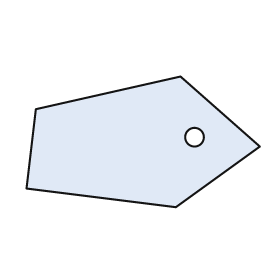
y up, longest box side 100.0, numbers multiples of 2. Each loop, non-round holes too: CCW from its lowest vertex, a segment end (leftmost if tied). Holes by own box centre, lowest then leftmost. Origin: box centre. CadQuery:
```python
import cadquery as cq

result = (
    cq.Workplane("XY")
    .moveTo(14.0, -28.0)
    .lineTo(50.0, -2.0)
    .lineTo(16.0, 28.0)
    .lineTo(-46.0, 14.0)
    .lineTo(-50.0, -20.0)
    .close()
    .moveTo(22.0, 2.0)
    .circle(4.0)
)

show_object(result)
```